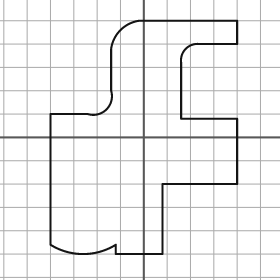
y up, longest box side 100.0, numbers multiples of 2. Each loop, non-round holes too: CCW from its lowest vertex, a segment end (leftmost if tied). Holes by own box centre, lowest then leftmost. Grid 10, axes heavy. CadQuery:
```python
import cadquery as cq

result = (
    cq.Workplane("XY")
    .moveTo(-12.0, -50.0)
    .lineTo(8.0, -50.0)
    .lineTo(8.0, -20.0)
    .lineTo(40.0, -20.0)
    .lineTo(40.0, 8.0)
    .lineTo(16.0, 8.0)
    .lineTo(16.0, 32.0)
    .threePointArc((18.0, 38.0), (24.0, 40.0))
    .lineTo(40.0, 40.0)
    .lineTo(40.0, 50.0)
    .lineTo(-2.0, 50.0)
    .threePointArc((-10.0, 46.0), (-14.0, 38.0))
    .lineTo(-14.0, 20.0)
    .threePointArc((-16.0, 12.0), (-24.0, 10.0))
    .lineTo(-40.0, 10.0)
    .lineTo(-40.0, -46.0)
    .threePointArc((-26.0, -50.0), (-12.0, -46.0))
    .close()
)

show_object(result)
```